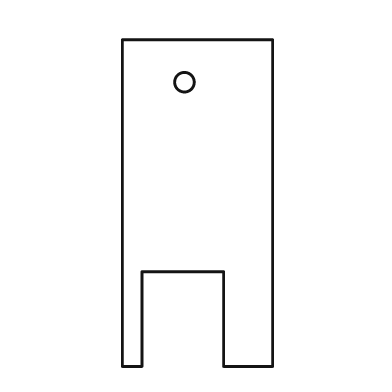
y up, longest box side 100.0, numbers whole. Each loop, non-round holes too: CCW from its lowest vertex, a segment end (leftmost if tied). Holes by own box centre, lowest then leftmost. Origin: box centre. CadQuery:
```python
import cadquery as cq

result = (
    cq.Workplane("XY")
    .moveTo(-23.0, -50.0)
    .lineTo(-17.0, -50.0)
    .lineTo(-17.0, -21.0)
    .lineTo(8.0, -21.0)
    .lineTo(8.0, -50.0)
    .lineTo(23.0, -50.0)
    .lineTo(23.0, 50.0)
    .lineTo(-23.0, 50.0)
    .close()
    .moveTo(-4.0, 37.0)
    .circle(3.0)
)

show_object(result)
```